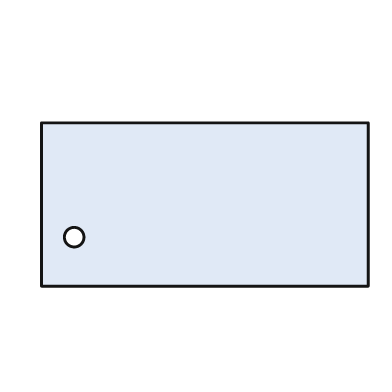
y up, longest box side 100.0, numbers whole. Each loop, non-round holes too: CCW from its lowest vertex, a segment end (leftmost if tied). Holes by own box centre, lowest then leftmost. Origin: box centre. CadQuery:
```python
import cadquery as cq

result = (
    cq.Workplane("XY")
    .moveTo(-50.0, -25.0)
    .lineTo(50.0, -25.0)
    .lineTo(50.0, 25.0)
    .lineTo(-50.0, 25.0)
    .close()
    .moveTo(-40.0, -10.0)
    .circle(3.0)
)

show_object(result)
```